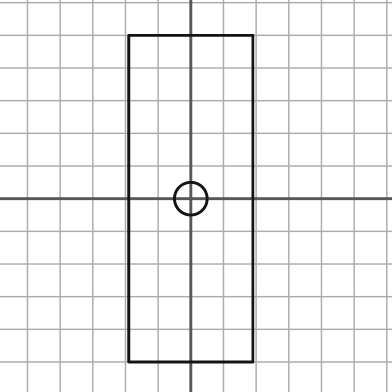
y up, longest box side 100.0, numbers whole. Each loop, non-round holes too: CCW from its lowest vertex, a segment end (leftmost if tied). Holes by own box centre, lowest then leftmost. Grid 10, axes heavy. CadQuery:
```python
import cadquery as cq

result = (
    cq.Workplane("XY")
    .moveTo(-19.0, -50.0)
    .lineTo(19.0, -50.0)
    .lineTo(19.0, 50.0)
    .lineTo(-19.0, 50.0)
    .close()
    .moveTo(0.0, 0.0)
    .circle(5.0)
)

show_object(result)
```